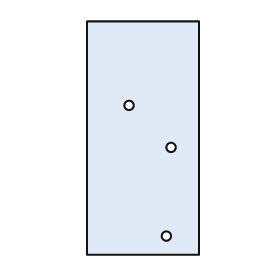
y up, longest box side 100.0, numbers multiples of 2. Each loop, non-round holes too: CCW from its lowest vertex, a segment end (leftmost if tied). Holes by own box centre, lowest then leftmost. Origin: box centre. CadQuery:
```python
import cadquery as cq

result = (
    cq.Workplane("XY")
    .moveTo(-24.0, -50.0)
    .lineTo(24.0, -50.0)
    .lineTo(24.0, 50.0)
    .lineTo(-24.0, 50.0)
    .close()
    .moveTo(10.0, -42.0)
    .circle(2.0)
    .moveTo(12.0, -4.0)
    .circle(2.0)
    .moveTo(-6.0, 14.0)
    .circle(2.0)
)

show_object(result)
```